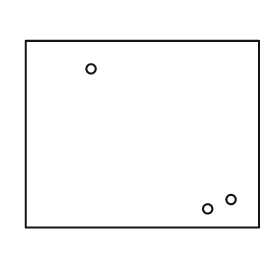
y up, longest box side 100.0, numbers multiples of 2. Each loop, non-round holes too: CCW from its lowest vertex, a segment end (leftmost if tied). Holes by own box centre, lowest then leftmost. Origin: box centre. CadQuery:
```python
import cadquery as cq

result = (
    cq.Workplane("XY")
    .moveTo(-50.0, -40.0)
    .lineTo(50.0, -40.0)
    .lineTo(50.0, 40.0)
    .lineTo(-50.0, 40.0)
    .close()
    .moveTo(28.0, -32.0)
    .circle(2.0)
    .moveTo(38.0, -28.0)
    .circle(2.0)
    .moveTo(-22.0, 28.0)
    .circle(2.0)
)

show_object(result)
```